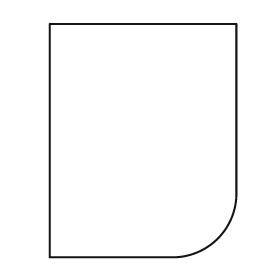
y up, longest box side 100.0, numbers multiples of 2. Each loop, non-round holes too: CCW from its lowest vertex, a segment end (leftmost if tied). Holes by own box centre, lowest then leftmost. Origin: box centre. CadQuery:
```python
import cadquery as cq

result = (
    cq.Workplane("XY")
    .moveTo(-40.0, -50.0)
    .lineTo(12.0, -50.0)
    .threePointArc((32.0, -42.0), (40.0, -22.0))
    .lineTo(40.0, 50.0)
    .lineTo(-40.0, 50.0)
    .close()
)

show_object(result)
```